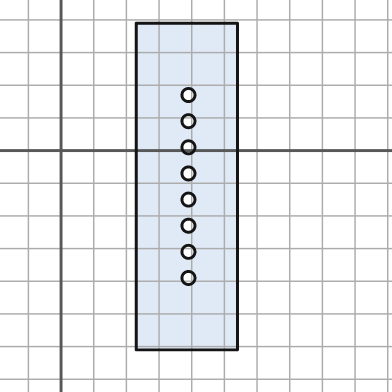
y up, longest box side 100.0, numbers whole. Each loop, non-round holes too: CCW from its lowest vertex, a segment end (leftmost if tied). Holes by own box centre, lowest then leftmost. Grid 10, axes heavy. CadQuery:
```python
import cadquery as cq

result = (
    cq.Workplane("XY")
    .moveTo(23.0, -61.0)
    .lineTo(54.0, -61.0)
    .lineTo(54.0, 39.0)
    .lineTo(23.0, 39.0)
    .close()
    .moveTo(39.0, -39.0)
    .circle(2.0)
    .moveTo(39.0, -31.0)
    .circle(2.0)
    .moveTo(39.0, -23.0)
    .circle(2.0)
    .moveTo(39.0, -15.0)
    .circle(2.0)
    .moveTo(39.0, -7.0)
    .circle(2.0)
    .moveTo(39.0, 1.0)
    .circle(2.0)
    .moveTo(39.0, 9.0)
    .circle(2.0)
    .moveTo(39.0, 17.0)
    .circle(2.0)
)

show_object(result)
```